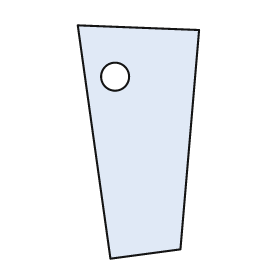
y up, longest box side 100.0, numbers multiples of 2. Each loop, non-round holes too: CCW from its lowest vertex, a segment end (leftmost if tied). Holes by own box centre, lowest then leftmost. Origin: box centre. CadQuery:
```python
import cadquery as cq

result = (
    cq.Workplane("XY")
    .moveTo(-12.0, -50.0)
    .lineTo(18.0, -46.0)
    .lineTo(26.0, 48.0)
    .lineTo(-26.0, 50.0)
    .close()
    .moveTo(-10.0, 28.0)
    .circle(6.0)
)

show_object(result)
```